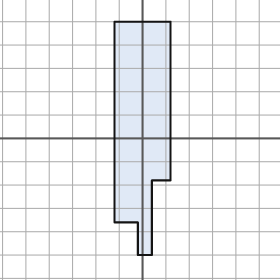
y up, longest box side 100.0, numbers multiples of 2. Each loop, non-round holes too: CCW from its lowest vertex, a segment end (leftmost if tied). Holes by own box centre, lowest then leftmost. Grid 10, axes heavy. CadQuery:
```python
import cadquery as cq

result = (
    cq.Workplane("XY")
    .moveTo(-2.0, -50.0)
    .lineTo(4.0, -50.0)
    .lineTo(4.0, -18.0)
    .lineTo(12.0, -18.0)
    .lineTo(12.0, 50.0)
    .lineTo(-12.0, 50.0)
    .lineTo(-12.0, -36.0)
    .lineTo(-2.0, -36.0)
    .close()
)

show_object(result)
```